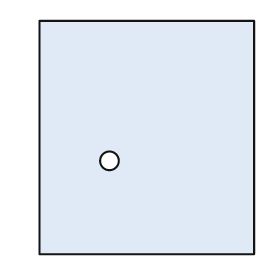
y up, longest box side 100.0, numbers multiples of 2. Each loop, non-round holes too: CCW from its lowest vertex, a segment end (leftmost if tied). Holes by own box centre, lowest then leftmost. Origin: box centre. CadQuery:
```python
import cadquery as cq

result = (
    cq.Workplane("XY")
    .moveTo(-46.0, -50.0)
    .lineTo(46.0, -50.0)
    .lineTo(46.0, 50.0)
    .lineTo(-46.0, 50.0)
    .close()
    .moveTo(-16.0, -10.0)
    .circle(4.0)
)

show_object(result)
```